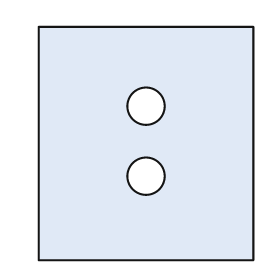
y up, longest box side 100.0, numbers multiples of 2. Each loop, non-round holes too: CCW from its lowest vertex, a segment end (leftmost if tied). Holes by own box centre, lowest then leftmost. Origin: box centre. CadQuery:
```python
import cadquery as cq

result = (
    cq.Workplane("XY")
    .moveTo(-46.0, -50.0)
    .lineTo(46.0, -50.0)
    .lineTo(46.0, 50.0)
    .lineTo(-46.0, 50.0)
    .close()
    .moveTo(0.0, -14.0)
    .circle(8.0)
    .moveTo(0.0, 16.0)
    .circle(8.0)
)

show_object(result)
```